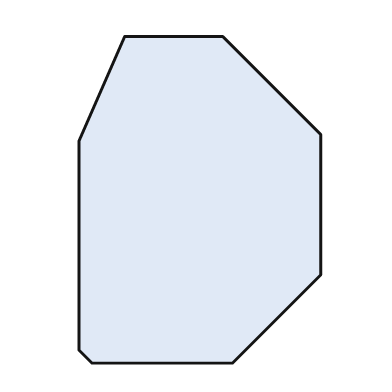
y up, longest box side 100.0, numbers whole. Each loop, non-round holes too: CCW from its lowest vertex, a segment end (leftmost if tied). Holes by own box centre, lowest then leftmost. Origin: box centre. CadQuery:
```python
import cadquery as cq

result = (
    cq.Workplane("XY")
    .moveTo(-33.0, -50.0)
    .lineTo(10.0, -50.0)
    .lineTo(37.0, -23.0)
    .lineTo(37.0, 20.0)
    .lineTo(7.0, 50.0)
    .lineTo(-23.0, 50.0)
    .lineTo(-37.0, 18.0)
    .lineTo(-37.0, -46.0)
    .close()
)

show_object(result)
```